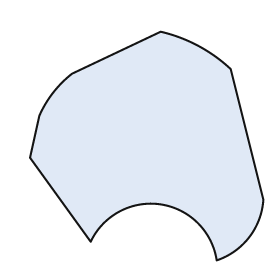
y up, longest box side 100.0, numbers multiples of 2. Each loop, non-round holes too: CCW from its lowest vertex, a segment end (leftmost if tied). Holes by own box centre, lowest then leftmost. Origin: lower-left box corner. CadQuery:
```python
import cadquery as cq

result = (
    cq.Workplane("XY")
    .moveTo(80.0, 0.0)
    .threePointArc((94.0, 10.0), (100.0, 26.0))
    .lineTo(86.0, 82.0)
    .threePointArc((72.0, 92.0), (56.0, 98.0))
    .lineTo(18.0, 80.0)
    .threePointArc((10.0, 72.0), (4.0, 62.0))
    .lineTo(0.0, 44.0)
    .lineTo(26.0, 8.0)
    .threePointArc((56.0, 24.0), (80.0, 0.0))
    .close()
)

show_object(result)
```